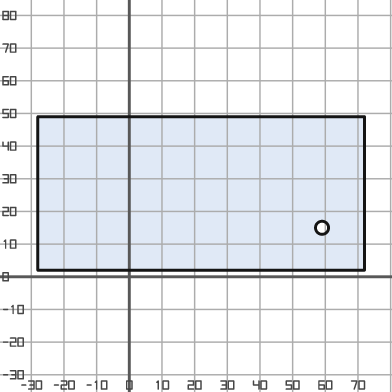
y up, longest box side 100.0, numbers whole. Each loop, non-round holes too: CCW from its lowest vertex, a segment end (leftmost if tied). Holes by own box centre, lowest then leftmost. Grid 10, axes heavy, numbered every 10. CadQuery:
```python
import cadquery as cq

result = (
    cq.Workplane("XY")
    .moveTo(-28.0, 2.0)
    .lineTo(72.0, 2.0)
    .lineTo(72.0, 49.0)
    .lineTo(-28.0, 49.0)
    .close()
    .moveTo(59.0, 15.0)
    .circle(2.0)
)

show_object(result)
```